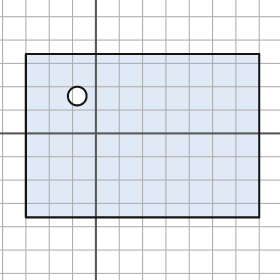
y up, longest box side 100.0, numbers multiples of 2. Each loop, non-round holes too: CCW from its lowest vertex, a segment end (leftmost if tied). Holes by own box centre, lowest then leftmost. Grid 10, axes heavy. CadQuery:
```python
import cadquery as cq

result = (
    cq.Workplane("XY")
    .moveTo(-30.0, -36.0)
    .lineTo(70.0, -36.0)
    .lineTo(70.0, 34.0)
    .lineTo(-30.0, 34.0)
    .close()
    .moveTo(-8.0, 16.0)
    .circle(4.0)
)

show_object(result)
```